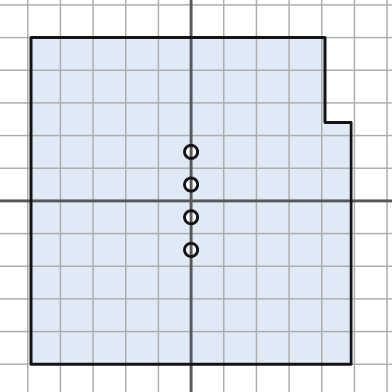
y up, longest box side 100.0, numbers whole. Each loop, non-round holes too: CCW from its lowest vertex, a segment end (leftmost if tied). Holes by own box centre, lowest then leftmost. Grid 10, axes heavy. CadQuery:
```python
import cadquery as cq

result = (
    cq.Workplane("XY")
    .moveTo(-49.0, -50.0)
    .lineTo(49.0, -50.0)
    .lineTo(49.0, 24.0)
    .lineTo(41.0, 24.0)
    .lineTo(41.0, 50.0)
    .lineTo(-49.0, 50.0)
    .close()
    .moveTo(0.0, -15.0)
    .circle(2.0)
    .moveTo(0.0, -5.0)
    .circle(2.0)
    .moveTo(0.0, 5.0)
    .circle(2.0)
    .moveTo(0.0, 15.0)
    .circle(2.0)
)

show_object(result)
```